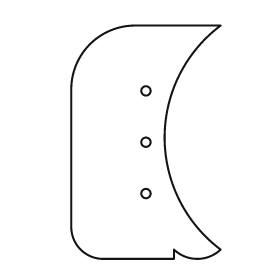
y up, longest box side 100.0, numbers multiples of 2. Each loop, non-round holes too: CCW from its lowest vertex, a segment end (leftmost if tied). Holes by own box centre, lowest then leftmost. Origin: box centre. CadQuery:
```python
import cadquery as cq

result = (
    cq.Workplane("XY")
    .moveTo(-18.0, -50.0)
    .lineTo(12.0, -50.0)
    .lineTo(12.0, -46.0)
    .threePointArc((22.0, -50.0), (32.0, -46.0))
    .threePointArc((8.0, 2.0), (32.0, 50.0))
    .lineTo(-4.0, 50.0)
    .threePointArc((-24.0, 42.0), (-32.0, 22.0))
    .lineTo(-32.0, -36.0)
    .threePointArc((-28.0, -46.0), (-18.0, -50.0))
    .close()
    .moveTo(0.0, -22.0)
    .circle(2.0)
    .moveTo(0.0, 0.0)
    .circle(2.0)
    .moveTo(0.0, 22.0)
    .circle(2.0)
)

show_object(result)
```